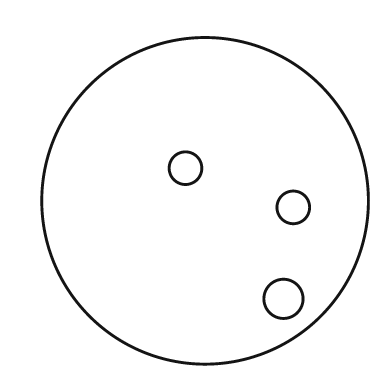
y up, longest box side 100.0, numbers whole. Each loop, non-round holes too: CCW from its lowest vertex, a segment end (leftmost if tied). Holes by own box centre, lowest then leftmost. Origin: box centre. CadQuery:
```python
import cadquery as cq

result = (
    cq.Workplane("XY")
    .moveTo(0.0, 0.0)
    .circle(50.0)
    .moveTo(24.0, -30.0)
    .circle(6.0)
    .moveTo(27.0, -2.0)
    .circle(5.0)
    .moveTo(-6.0, 10.0)
    .circle(5.0)
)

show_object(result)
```